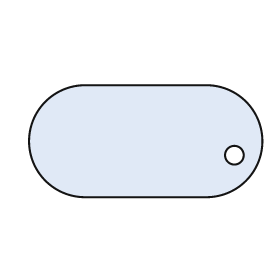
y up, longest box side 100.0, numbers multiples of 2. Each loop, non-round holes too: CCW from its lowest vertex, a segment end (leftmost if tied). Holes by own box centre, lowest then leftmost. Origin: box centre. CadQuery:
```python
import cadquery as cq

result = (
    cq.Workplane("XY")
    .moveTo(-26.0, -24.0)
    .lineTo(26.0, -24.0)
    .threePointArc((50.0, 0.0), (26.0, 24.0))
    .lineTo(-26.0, 24.0)
    .threePointArc((-50.0, 0.0), (-26.0, -24.0))
    .close()
    .moveTo(38.0, -6.0)
    .circle(4.0)
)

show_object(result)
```